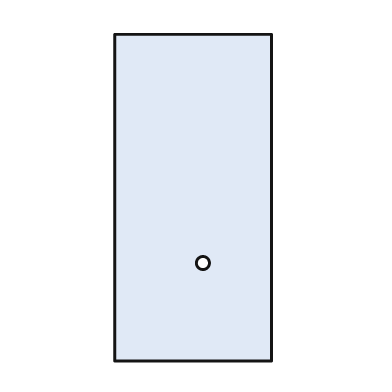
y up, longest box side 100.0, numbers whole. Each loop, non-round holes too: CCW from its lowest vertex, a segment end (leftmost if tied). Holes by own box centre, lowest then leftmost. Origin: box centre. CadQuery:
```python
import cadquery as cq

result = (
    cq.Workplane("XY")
    .moveTo(-24.0, -50.0)
    .lineTo(24.0, -50.0)
    .lineTo(24.0, 50.0)
    .lineTo(-24.0, 50.0)
    .close()
    .moveTo(3.0, -20.0)
    .circle(2.0)
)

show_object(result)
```